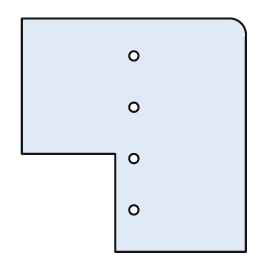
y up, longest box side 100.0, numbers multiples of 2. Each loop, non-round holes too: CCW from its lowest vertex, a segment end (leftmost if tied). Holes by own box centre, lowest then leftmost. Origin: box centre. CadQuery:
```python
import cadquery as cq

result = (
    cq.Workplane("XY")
    .moveTo(-8.0, -50.0)
    .lineTo(48.0, -50.0)
    .lineTo(48.0, 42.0)
    .threePointArc((46.0, 48.0), (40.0, 50.0))
    .lineTo(-48.0, 50.0)
    .lineTo(-48.0, -8.0)
    .lineTo(-8.0, -8.0)
    .close()
    .moveTo(0.0, -32.0)
    .circle(2.0)
    .moveTo(0.0, -10.0)
    .circle(2.0)
    .moveTo(0.0, 12.0)
    .circle(2.0)
    .moveTo(0.0, 34.0)
    .circle(2.0)
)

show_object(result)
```